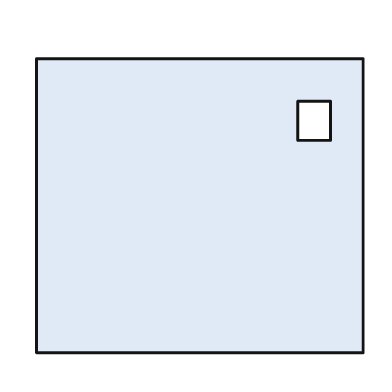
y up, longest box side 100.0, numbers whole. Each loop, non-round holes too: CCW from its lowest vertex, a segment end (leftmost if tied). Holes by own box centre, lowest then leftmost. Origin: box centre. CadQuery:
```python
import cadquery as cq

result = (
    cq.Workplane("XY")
    .moveTo(-50.0, -45.0)
    .lineTo(50.0, -45.0)
    .lineTo(50.0, 45.0)
    .lineTo(-50.0, 45.0)
    .close()
    .moveTo(30.0, 20.0)
    .lineTo(40.0, 20.0)
    .lineTo(40.0, 32.0)
    .lineTo(30.0, 32.0)
    .close()
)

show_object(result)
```